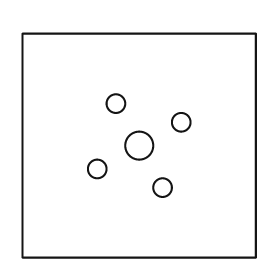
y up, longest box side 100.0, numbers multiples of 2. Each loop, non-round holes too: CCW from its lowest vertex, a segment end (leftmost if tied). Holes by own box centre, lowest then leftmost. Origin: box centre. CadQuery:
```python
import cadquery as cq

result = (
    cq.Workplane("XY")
    .moveTo(-50.0, -48.0)
    .lineTo(50.0, -48.0)
    .lineTo(50.0, 48.0)
    .lineTo(-50.0, 48.0)
    .close()
    .moveTo(10.0, -18.0)
    .circle(4.0)
    .moveTo(-18.0, -10.0)
    .circle(4.0)
    .moveTo(0.0, 0.0)
    .circle(6.0)
    .moveTo(18.0, 10.0)
    .circle(4.0)
    .moveTo(-10.0, 18.0)
    .circle(4.0)
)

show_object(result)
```